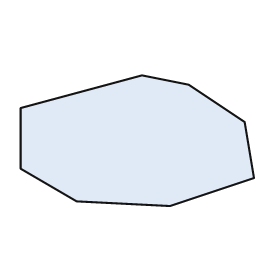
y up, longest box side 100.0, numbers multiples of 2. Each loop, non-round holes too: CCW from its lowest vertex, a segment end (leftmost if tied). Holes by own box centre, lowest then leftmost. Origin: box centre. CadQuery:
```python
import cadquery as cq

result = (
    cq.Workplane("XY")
    .moveTo(14.0, -28.0)
    .lineTo(50.0, -16.0)
    .lineTo(46.0, 8.0)
    .lineTo(22.0, 24.0)
    .lineTo(2.0, 28.0)
    .lineTo(-50.0, 14.0)
    .lineTo(-50.0, -12.0)
    .lineTo(-26.0, -26.0)
    .close()
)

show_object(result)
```